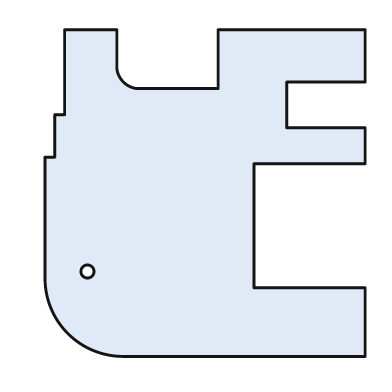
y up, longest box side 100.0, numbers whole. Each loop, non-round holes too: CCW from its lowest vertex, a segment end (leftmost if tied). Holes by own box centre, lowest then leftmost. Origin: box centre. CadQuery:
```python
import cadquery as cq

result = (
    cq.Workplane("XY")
    .moveTo(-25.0, -50.0)
    .lineTo(49.0, -50.0)
    .lineTo(49.0, -29.0)
    .lineTo(15.0, -29.0)
    .lineTo(15.0, 9.0)
    .lineTo(49.0, 9.0)
    .lineTo(49.0, 20.0)
    .lineTo(25.0, 20.0)
    .lineTo(25.0, 34.0)
    .lineTo(49.0, 34.0)
    .lineTo(49.0, 50.0)
    .lineTo(4.0, 50.0)
    .lineTo(4.0, 32.0)
    .lineTo(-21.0, 32.0)
    .threePointArc((-25.0, 34.0), (-27.0, 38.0))
    .lineTo(-27.0, 50.0)
    .lineTo(-43.0, 50.0)
    .lineTo(-43.0, 24.0)
    .lineTo(-46.0, 24.0)
    .lineTo(-46.0, 11.0)
    .lineTo(-49.0, 11.0)
    .lineTo(-49.0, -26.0)
    .threePointArc((-42.0, -43.0), (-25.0, -50.0))
    .close()
    .moveTo(-36.0, -24.0)
    .circle(2.0)
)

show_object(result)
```